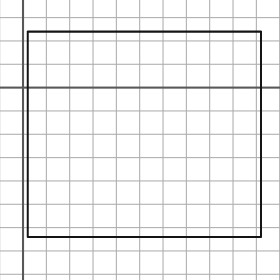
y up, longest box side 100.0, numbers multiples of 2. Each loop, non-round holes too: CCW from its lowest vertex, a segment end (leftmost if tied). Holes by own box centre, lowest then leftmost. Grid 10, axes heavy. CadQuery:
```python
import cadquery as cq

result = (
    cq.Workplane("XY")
    .moveTo(2.0, -64.0)
    .lineTo(102.0, -64.0)
    .lineTo(102.0, 24.0)
    .lineTo(2.0, 24.0)
    .close()
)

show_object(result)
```